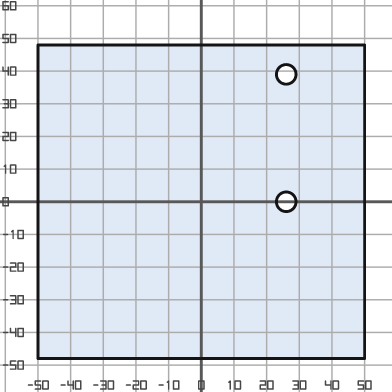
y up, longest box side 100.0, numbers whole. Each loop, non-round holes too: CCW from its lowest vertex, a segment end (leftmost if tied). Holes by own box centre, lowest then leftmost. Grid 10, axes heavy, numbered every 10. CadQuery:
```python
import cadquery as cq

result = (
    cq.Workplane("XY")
    .moveTo(-50.0, -48.0)
    .lineTo(50.0, -48.0)
    .lineTo(50.0, 48.0)
    .lineTo(-50.0, 48.0)
    .close()
    .moveTo(26.0, 0.0)
    .circle(3.0)
    .moveTo(26.0, 39.0)
    .circle(3.0)
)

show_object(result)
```